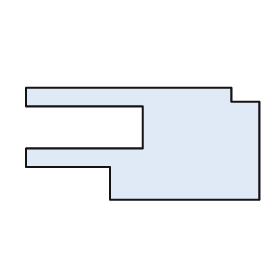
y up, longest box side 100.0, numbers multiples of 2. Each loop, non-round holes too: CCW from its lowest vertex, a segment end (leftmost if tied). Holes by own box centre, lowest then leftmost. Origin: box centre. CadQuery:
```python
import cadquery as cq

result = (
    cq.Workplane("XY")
    .moveTo(-14.0, -24.0)
    .lineTo(50.0, -24.0)
    .lineTo(50.0, 18.0)
    .lineTo(38.0, 18.0)
    .lineTo(38.0, 24.0)
    .lineTo(-50.0, 24.0)
    .lineTo(-50.0, 16.0)
    .lineTo(0.0, 16.0)
    .lineTo(0.0, -2.0)
    .lineTo(-50.0, -2.0)
    .lineTo(-50.0, -10.0)
    .lineTo(-14.0, -10.0)
    .close()
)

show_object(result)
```